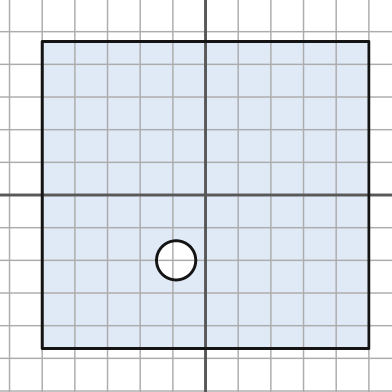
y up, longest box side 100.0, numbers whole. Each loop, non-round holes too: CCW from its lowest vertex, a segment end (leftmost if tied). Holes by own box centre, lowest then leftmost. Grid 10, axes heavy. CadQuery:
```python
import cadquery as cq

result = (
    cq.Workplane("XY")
    .moveTo(-50.0, -47.0)
    .lineTo(50.0, -47.0)
    .lineTo(50.0, 47.0)
    .lineTo(-50.0, 47.0)
    .close()
    .moveTo(-9.0, -20.0)
    .circle(6.0)
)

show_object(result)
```